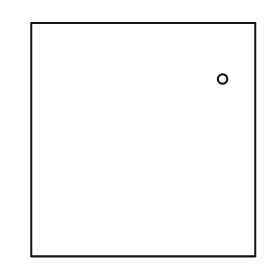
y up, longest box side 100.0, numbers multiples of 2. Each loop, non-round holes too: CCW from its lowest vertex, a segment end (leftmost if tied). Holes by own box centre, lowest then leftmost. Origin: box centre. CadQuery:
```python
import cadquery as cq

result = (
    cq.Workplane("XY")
    .moveTo(-48.0, -50.0)
    .lineTo(48.0, -50.0)
    .lineTo(48.0, 50.0)
    .lineTo(-48.0, 50.0)
    .close()
    .moveTo(34.0, 26.0)
    .circle(2.0)
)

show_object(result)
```